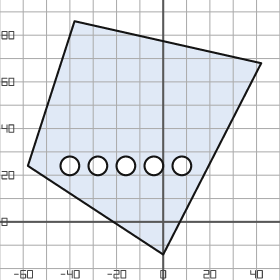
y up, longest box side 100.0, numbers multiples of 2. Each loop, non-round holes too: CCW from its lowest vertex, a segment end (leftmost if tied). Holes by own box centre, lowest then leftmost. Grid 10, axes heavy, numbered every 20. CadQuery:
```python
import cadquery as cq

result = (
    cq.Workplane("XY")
    .moveTo(0.0, -14.0)
    .lineTo(42.0, 68.0)
    .lineTo(-38.0, 86.0)
    .lineTo(-58.0, 24.0)
    .close()
    .moveTo(-40.0, 24.0)
    .circle(4.0)
    .moveTo(-28.0, 24.0)
    .circle(4.0)
    .moveTo(-16.0, 24.0)
    .circle(4.0)
    .moveTo(-4.0, 24.0)
    .circle(4.0)
    .moveTo(8.0, 24.0)
    .circle(4.0)
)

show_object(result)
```